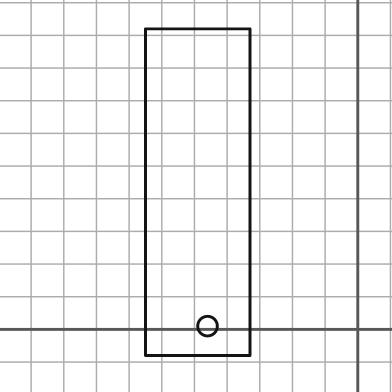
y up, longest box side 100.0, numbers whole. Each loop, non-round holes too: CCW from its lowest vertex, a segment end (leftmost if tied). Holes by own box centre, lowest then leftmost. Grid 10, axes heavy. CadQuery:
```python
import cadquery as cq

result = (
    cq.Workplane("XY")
    .moveTo(-65.0, -8.0)
    .lineTo(-33.0, -8.0)
    .lineTo(-33.0, 92.0)
    .lineTo(-65.0, 92.0)
    .close()
    .moveTo(-46.0, 1.0)
    .circle(3.0)
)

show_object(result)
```